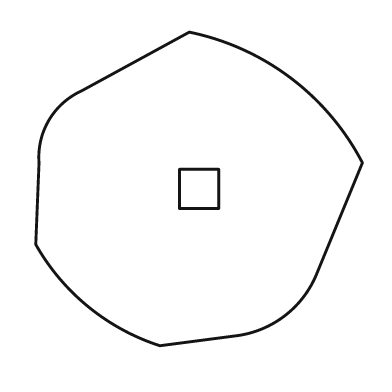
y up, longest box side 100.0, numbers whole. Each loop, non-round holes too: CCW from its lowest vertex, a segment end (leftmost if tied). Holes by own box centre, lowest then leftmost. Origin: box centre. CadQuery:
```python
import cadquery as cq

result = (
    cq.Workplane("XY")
    .moveTo(-12.0, -48.0)
    .lineTo(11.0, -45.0)
    .threePointArc((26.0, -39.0), (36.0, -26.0))
    .lineTo(50.0, 8.0)
    .threePointArc((28.0, 34.0), (-3.0, 48.0))
    .lineTo(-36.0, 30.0)
    .threePointArc((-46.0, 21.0), (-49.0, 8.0))
    .lineTo(-50.0, -17.0)
    .threePointArc((-34.0, -36.0), (-12.0, -48.0))
    .close()
    .moveTo(-6.0, -6.0)
    .lineTo(6.0, -6.0)
    .lineTo(6.0, 6.0)
    .lineTo(-6.0, 6.0)
    .close()
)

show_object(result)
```